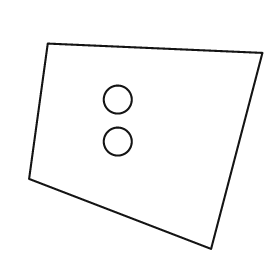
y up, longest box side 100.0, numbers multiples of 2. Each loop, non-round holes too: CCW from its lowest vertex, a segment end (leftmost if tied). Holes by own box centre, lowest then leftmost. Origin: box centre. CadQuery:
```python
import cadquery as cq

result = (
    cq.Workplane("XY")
    .moveTo(28.0, -44.0)
    .lineTo(50.0, 40.0)
    .lineTo(-42.0, 44.0)
    .lineTo(-50.0, -14.0)
    .close()
    .moveTo(-12.0, 2.0)
    .circle(6.0)
    .moveTo(-12.0, 20.0)
    .circle(6.0)
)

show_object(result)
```